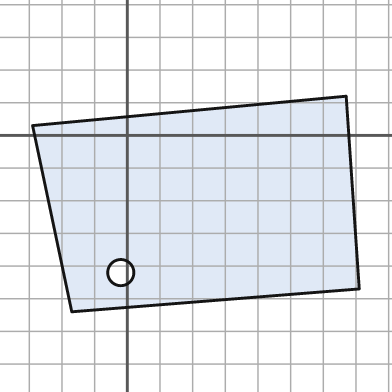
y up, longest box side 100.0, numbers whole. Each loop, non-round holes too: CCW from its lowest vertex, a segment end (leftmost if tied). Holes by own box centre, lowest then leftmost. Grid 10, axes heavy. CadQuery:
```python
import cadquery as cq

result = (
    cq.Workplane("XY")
    .moveTo(-17.0, -54.0)
    .lineTo(71.0, -47.0)
    .lineTo(67.0, 12.0)
    .lineTo(-29.0, 3.0)
    .close()
    .moveTo(-2.0, -42.0)
    .circle(4.0)
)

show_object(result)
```